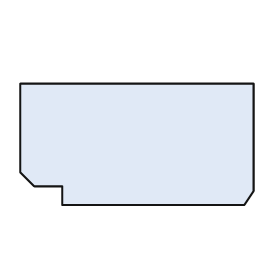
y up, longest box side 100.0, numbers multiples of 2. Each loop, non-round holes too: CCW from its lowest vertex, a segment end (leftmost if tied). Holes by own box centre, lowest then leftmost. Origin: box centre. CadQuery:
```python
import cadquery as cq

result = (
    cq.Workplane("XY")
    .moveTo(-32.0, -26.0)
    .lineTo(46.0, -26.0)
    .lineTo(50.0, -20.0)
    .lineTo(50.0, 26.0)
    .lineTo(-50.0, 26.0)
    .lineTo(-50.0, -12.0)
    .lineTo(-44.0, -18.0)
    .lineTo(-32.0, -18.0)
    .close()
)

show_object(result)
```